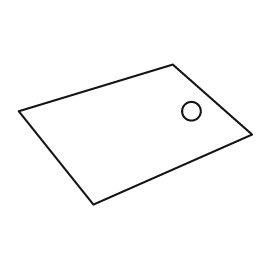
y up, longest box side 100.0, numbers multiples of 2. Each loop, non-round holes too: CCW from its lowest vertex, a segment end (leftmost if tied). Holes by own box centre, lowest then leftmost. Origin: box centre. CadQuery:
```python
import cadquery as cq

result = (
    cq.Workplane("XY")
    .moveTo(-18.0, -30.0)
    .lineTo(50.0, 0.0)
    .lineTo(16.0, 30.0)
    .lineTo(-50.0, 10.0)
    .close()
    .moveTo(24.0, 10.0)
    .circle(4.0)
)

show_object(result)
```